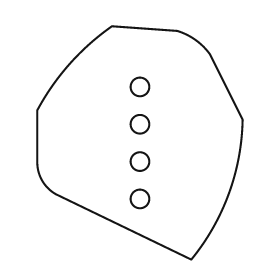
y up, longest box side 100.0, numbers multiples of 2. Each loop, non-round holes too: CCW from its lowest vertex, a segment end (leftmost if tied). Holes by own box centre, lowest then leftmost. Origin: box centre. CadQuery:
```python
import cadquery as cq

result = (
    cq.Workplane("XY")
    .moveTo(22.0, -50.0)
    .threePointArc((38.0, -22.0), (44.0, 10.0))
    .lineTo(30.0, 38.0)
    .threePointArc((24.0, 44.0), (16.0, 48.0))
    .lineTo(-12.0, 50.0)
    .threePointArc((-30.0, 34.0), (-44.0, 14.0))
    .lineTo(-44.0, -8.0)
    .threePointArc((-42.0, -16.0), (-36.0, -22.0))
    .close()
    .moveTo(0.0, -24.0)
    .circle(4.0)
    .moveTo(0.0, -8.0)
    .circle(4.0)
    .moveTo(0.0, 8.0)
    .circle(4.0)
    .moveTo(0.0, 24.0)
    .circle(4.0)
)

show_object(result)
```